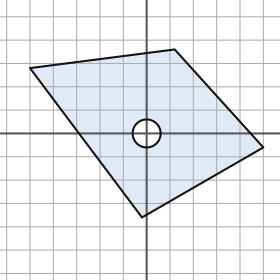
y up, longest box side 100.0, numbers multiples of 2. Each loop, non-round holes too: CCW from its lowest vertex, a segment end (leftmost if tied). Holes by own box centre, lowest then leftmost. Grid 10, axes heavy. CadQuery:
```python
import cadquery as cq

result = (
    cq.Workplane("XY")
    .moveTo(-2.0, -36.0)
    .lineTo(50.0, -6.0)
    .lineTo(12.0, 36.0)
    .lineTo(-50.0, 28.0)
    .close()
    .moveTo(0.0, 0.0)
    .circle(6.0)
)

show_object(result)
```